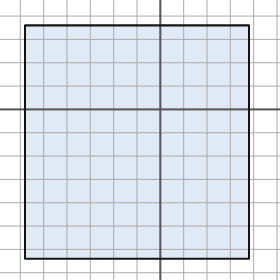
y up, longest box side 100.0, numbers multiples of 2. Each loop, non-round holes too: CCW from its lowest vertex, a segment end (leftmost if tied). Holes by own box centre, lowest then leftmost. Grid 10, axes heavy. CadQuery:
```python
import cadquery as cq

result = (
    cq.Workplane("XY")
    .moveTo(-58.0, -64.0)
    .lineTo(38.0, -64.0)
    .lineTo(38.0, 36.0)
    .lineTo(-58.0, 36.0)
    .close()
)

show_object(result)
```